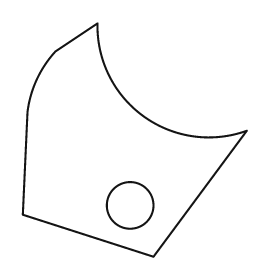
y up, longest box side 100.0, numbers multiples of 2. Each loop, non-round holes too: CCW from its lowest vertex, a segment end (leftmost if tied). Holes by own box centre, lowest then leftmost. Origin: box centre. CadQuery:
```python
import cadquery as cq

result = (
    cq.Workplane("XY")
    .moveTo(8.0, -50.0)
    .lineTo(48.0, 4.0)
    .threePointArc((4.0, 10.0), (-16.0, 50.0))
    .lineTo(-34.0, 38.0)
    .threePointArc((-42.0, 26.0), (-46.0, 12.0))
    .lineTo(-48.0, -32.0)
    .close()
    .moveTo(-2.0, -28.0)
    .circle(10.0)
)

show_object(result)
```